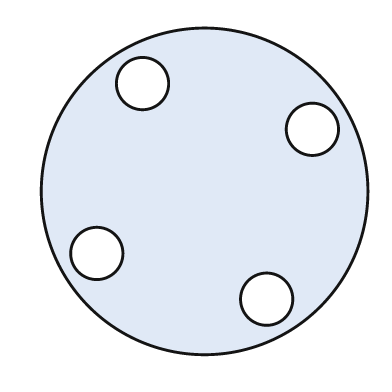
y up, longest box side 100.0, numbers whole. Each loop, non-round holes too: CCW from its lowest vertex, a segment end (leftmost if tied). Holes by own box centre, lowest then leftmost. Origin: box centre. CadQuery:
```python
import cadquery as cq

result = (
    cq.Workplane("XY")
    .moveTo(0.0, 0.0)
    .circle(50.0)
    .moveTo(19.0, -33.0)
    .circle(8.0)
    .moveTo(-33.0, -19.0)
    .circle(8.0)
    .moveTo(33.0, 19.0)
    .circle(8.0)
    .moveTo(-19.0, 33.0)
    .circle(8.0)
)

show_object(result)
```